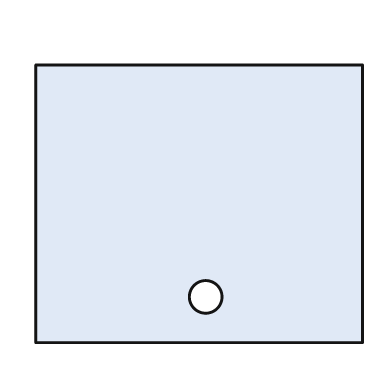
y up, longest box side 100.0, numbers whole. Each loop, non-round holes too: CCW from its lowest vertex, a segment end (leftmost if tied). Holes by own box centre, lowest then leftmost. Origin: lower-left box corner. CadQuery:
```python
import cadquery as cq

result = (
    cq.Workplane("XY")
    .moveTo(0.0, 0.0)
    .lineTo(100.0, 0.0)
    .lineTo(100.0, 85.0)
    .lineTo(0.0, 85.0)
    .close()
    .moveTo(52.0, 14.0)
    .circle(5.0)
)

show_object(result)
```